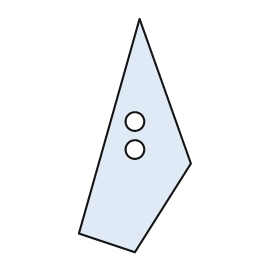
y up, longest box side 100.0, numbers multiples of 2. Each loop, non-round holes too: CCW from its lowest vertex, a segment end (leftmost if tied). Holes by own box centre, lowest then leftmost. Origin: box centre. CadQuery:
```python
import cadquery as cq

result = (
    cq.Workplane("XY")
    .moveTo(0.0, -50.0)
    .lineTo(24.0, -12.0)
    .lineTo(2.0, 50.0)
    .lineTo(-24.0, -42.0)
    .close()
    .moveTo(0.0, -6.0)
    .circle(4.0)
    .moveTo(0.0, 6.0)
    .circle(4.0)
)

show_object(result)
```